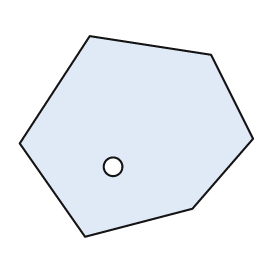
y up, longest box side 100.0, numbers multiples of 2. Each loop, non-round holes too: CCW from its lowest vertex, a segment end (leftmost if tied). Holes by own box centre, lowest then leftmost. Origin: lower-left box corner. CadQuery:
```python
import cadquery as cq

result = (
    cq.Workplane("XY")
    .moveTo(28.0, 0.0)
    .lineTo(74.0, 12.0)
    .lineTo(100.0, 42.0)
    .lineTo(82.0, 78.0)
    .lineTo(30.0, 86.0)
    .lineTo(0.0, 40.0)
    .close()
    .moveTo(40.0, 30.0)
    .circle(4.0)
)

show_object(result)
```